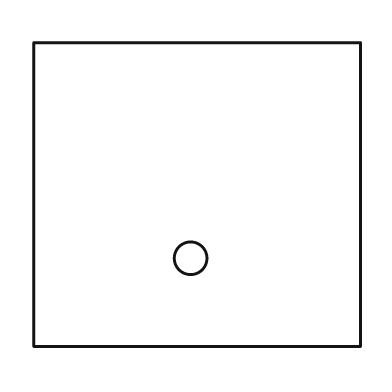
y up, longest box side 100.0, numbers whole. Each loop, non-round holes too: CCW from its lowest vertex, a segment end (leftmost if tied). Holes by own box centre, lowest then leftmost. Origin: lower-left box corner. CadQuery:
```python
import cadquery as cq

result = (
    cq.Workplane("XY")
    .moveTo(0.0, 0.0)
    .lineTo(100.0, 0.0)
    .lineTo(100.0, 93.0)
    .lineTo(0.0, 93.0)
    .close()
    .moveTo(48.0, 27.0)
    .circle(5.0)
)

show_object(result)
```